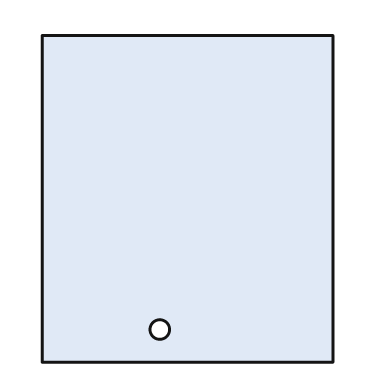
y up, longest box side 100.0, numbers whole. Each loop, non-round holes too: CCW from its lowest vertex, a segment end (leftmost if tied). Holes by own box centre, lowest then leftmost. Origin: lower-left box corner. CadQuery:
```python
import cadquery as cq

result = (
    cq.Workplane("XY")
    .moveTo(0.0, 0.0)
    .lineTo(89.0, 0.0)
    .lineTo(89.0, 100.0)
    .lineTo(0.0, 100.0)
    .close()
    .moveTo(36.0, 10.0)
    .circle(3.0)
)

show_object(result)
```